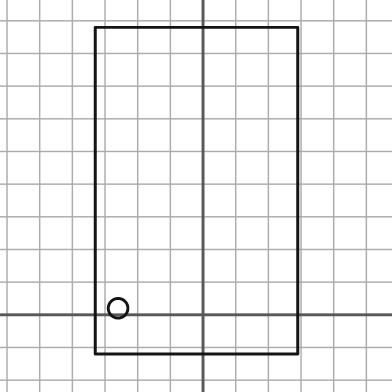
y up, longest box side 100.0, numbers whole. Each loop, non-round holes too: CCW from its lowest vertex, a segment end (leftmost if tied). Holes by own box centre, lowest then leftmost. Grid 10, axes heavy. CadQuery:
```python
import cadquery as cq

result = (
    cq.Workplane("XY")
    .moveTo(-33.0, -12.0)
    .lineTo(29.0, -12.0)
    .lineTo(29.0, 88.0)
    .lineTo(-33.0, 88.0)
    .close()
    .moveTo(-26.0, 2.0)
    .circle(3.0)
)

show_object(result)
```